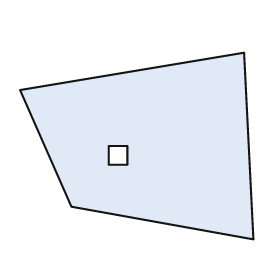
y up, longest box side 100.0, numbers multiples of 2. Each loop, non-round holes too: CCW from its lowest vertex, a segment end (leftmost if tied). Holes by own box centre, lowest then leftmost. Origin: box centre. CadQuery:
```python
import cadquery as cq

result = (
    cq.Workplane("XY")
    .moveTo(50.0, -40.0)
    .lineTo(46.0, 40.0)
    .lineTo(-50.0, 24.0)
    .lineTo(-28.0, -26.0)
    .close()
    .moveTo(-12.0, -8.0)
    .lineTo(-4.0, -8.0)
    .lineTo(-4.0, 0.0)
    .lineTo(-12.0, 0.0)
    .close()
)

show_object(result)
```